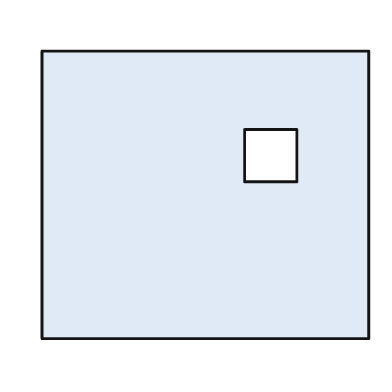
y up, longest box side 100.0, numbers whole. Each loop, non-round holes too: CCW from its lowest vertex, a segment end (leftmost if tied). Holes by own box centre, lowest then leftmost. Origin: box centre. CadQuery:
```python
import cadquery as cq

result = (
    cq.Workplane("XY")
    .moveTo(-50.0, -44.0)
    .lineTo(50.0, -44.0)
    .lineTo(50.0, 44.0)
    .lineTo(-50.0, 44.0)
    .close()
    .moveTo(12.0, 4.0)
    .lineTo(28.0, 4.0)
    .lineTo(28.0, 20.0)
    .lineTo(12.0, 20.0)
    .close()
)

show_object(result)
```